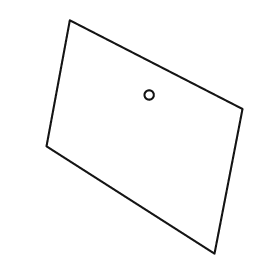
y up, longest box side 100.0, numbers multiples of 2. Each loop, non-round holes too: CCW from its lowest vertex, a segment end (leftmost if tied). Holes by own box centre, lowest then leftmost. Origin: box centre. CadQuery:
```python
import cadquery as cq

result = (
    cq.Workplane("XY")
    .moveTo(30.0, -50.0)
    .lineTo(42.0, 12.0)
    .lineTo(-32.0, 50.0)
    .lineTo(-42.0, -4.0)
    .close()
    .moveTo(2.0, 18.0)
    .circle(2.0)
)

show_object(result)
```